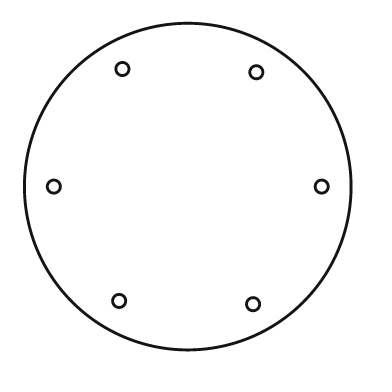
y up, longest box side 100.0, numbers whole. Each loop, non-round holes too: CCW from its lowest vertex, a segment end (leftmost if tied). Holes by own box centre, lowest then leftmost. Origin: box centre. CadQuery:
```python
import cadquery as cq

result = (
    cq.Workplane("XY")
    .moveTo(0.0, 0.0)
    .circle(50.0)
    .moveTo(20.0, -36.0)
    .circle(2.0)
    .moveTo(-21.0, -35.0)
    .circle(2.0)
    .moveTo(-41.0, 0.0)
    .circle(2.0)
    .moveTo(41.0, 0.0)
    .circle(2.0)
    .moveTo(21.0, 35.0)
    .circle(2.0)
    .moveTo(-20.0, 36.0)
    .circle(2.0)
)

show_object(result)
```